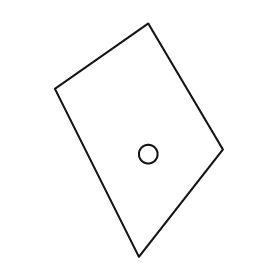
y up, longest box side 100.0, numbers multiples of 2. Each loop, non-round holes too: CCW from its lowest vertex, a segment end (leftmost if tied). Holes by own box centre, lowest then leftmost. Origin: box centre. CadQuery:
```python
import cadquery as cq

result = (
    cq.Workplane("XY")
    .moveTo(0.0, -50.0)
    .lineTo(36.0, -4.0)
    .lineTo(4.0, 50.0)
    .lineTo(-36.0, 22.0)
    .close()
    .moveTo(4.0, -6.0)
    .circle(4.0)
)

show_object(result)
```